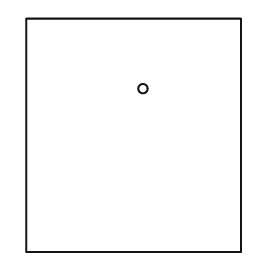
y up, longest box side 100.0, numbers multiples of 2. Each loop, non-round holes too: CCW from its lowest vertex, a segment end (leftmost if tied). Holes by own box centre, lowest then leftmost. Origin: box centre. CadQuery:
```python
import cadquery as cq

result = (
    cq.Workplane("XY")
    .moveTo(-46.0, -50.0)
    .lineTo(46.0, -50.0)
    .lineTo(46.0, 50.0)
    .lineTo(-46.0, 50.0)
    .close()
    .moveTo(4.0, 20.0)
    .circle(2.0)
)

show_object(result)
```